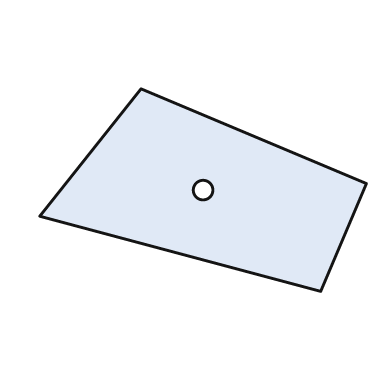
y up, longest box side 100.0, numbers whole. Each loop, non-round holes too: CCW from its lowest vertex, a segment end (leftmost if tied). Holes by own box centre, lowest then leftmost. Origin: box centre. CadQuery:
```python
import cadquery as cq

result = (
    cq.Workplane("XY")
    .moveTo(36.0, -31.0)
    .lineTo(50.0, 2.0)
    .lineTo(-19.0, 31.0)
    .lineTo(-50.0, -8.0)
    .close()
    .moveTo(0.0, 0.0)
    .circle(3.0)
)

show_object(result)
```